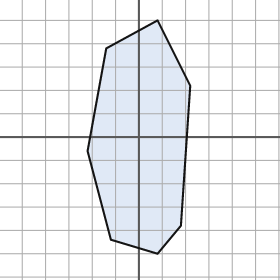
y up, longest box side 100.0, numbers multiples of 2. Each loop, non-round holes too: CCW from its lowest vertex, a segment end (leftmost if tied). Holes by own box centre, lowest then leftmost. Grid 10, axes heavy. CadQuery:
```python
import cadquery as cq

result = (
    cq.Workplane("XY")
    .moveTo(8.0, -50.0)
    .lineTo(18.0, -38.0)
    .lineTo(22.0, 22.0)
    .lineTo(8.0, 50.0)
    .lineTo(-14.0, 38.0)
    .lineTo(-22.0, -6.0)
    .lineTo(-12.0, -44.0)
    .close()
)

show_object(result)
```